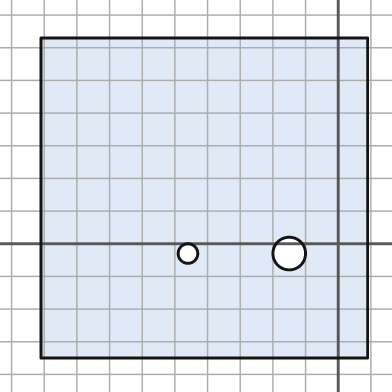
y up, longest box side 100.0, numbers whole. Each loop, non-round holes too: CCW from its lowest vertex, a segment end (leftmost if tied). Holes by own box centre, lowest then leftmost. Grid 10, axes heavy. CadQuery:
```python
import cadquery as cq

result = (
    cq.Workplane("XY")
    .moveTo(-91.0, -35.0)
    .lineTo(9.0, -35.0)
    .lineTo(9.0, 63.0)
    .lineTo(-91.0, 63.0)
    .close()
    .moveTo(-46.0, -3.0)
    .circle(3.0)
    .moveTo(-15.0, -3.0)
    .circle(5.0)
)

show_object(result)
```